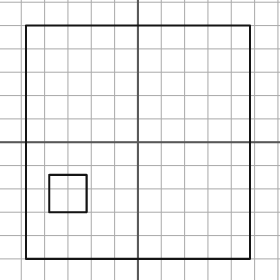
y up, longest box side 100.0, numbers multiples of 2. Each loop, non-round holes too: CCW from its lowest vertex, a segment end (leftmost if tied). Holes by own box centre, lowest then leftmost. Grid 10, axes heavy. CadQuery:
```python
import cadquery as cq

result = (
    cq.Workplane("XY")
    .moveTo(-48.0, -50.0)
    .lineTo(48.0, -50.0)
    .lineTo(48.0, 50.0)
    .lineTo(-48.0, 50.0)
    .close()
    .moveTo(-38.0, -30.0)
    .lineTo(-22.0, -30.0)
    .lineTo(-22.0, -14.0)
    .lineTo(-38.0, -14.0)
    .close()
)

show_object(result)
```